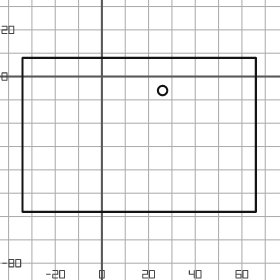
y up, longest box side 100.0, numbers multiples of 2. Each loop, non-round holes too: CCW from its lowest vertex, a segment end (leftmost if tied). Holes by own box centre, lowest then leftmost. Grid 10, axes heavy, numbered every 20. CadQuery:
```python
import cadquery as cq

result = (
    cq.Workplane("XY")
    .moveTo(-34.0, -58.0)
    .lineTo(66.0, -58.0)
    .lineTo(66.0, 8.0)
    .lineTo(-34.0, 8.0)
    .close()
    .moveTo(26.0, -6.0)
    .circle(2.0)
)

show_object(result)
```